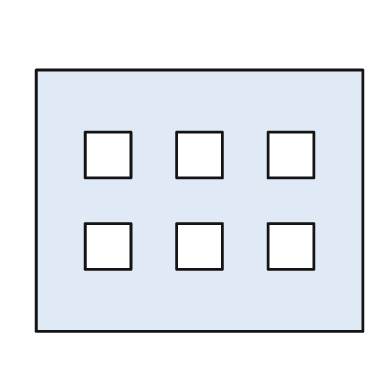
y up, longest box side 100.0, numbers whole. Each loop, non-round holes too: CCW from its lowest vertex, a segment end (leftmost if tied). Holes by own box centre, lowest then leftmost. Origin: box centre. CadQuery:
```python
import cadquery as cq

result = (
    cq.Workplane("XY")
    .moveTo(-50.0, -40.0)
    .lineTo(50.0, -40.0)
    .lineTo(50.0, 40.0)
    .lineTo(-50.0, 40.0)
    .close()
    .moveTo(-35.0, -21.0)
    .lineTo(-21.0, -21.0)
    .lineTo(-21.0, -7.0)
    .lineTo(-35.0, -7.0)
    .close()
    .moveTo(-7.0, -21.0)
    .lineTo(7.0, -21.0)
    .lineTo(7.0, -7.0)
    .lineTo(-7.0, -7.0)
    .close()
    .moveTo(21.0, -21.0)
    .lineTo(35.0, -21.0)
    .lineTo(35.0, -7.0)
    .lineTo(21.0, -7.0)
    .close()
    .moveTo(-35.0, 7.0)
    .lineTo(-21.0, 7.0)
    .lineTo(-21.0, 21.0)
    .lineTo(-35.0, 21.0)
    .close()
    .moveTo(-7.0, 7.0)
    .lineTo(7.0, 7.0)
    .lineTo(7.0, 21.0)
    .lineTo(-7.0, 21.0)
    .close()
    .moveTo(21.0, 7.0)
    .lineTo(35.0, 7.0)
    .lineTo(35.0, 21.0)
    .lineTo(21.0, 21.0)
    .close()
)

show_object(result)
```